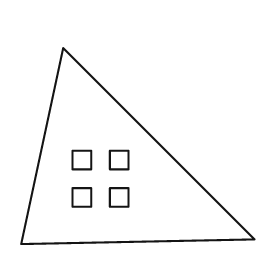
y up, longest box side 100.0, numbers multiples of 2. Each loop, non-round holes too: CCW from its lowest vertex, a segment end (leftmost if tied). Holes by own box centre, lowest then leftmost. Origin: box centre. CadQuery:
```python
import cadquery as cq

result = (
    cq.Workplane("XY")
    .moveTo(-50.0, -42.0)
    .lineTo(50.0, -40.0)
    .lineTo(-32.0, 42.0)
    .close()
    .moveTo(-28.0, -26.0)
    .lineTo(-20.0, -26.0)
    .lineTo(-20.0, -18.0)
    .lineTo(-28.0, -18.0)
    .close()
    .moveTo(-12.0, -26.0)
    .lineTo(-4.0, -26.0)
    .lineTo(-4.0, -18.0)
    .lineTo(-12.0, -18.0)
    .close()
    .moveTo(-28.0, -10.0)
    .lineTo(-20.0, -10.0)
    .lineTo(-20.0, -2.0)
    .lineTo(-28.0, -2.0)
    .close()
    .moveTo(-12.0, -10.0)
    .lineTo(-4.0, -10.0)
    .lineTo(-4.0, -2.0)
    .lineTo(-12.0, -2.0)
    .close()
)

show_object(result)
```